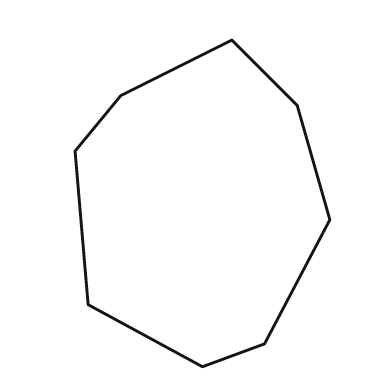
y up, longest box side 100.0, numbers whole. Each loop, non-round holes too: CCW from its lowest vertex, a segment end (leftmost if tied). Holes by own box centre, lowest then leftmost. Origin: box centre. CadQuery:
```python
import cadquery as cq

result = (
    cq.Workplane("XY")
    .moveTo(0.0, -50.0)
    .lineTo(19.0, -43.0)
    .lineTo(39.0, -5.0)
    .lineTo(29.0, 30.0)
    .lineTo(9.0, 50.0)
    .lineTo(-25.0, 33.0)
    .lineTo(-39.0, 16.0)
    .lineTo(-35.0, -31.0)
    .close()
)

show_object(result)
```